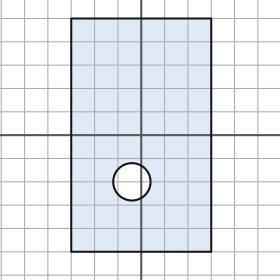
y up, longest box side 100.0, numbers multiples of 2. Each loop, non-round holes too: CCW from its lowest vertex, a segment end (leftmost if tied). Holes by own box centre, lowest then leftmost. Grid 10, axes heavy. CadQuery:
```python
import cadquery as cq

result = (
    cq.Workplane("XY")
    .moveTo(-30.0, -50.0)
    .lineTo(30.0, -50.0)
    .lineTo(30.0, 50.0)
    .lineTo(-30.0, 50.0)
    .close()
    .moveTo(-4.0, -20.0)
    .circle(8.0)
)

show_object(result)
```